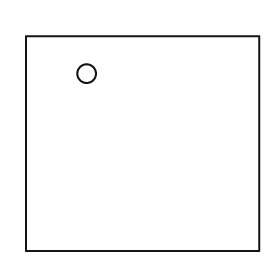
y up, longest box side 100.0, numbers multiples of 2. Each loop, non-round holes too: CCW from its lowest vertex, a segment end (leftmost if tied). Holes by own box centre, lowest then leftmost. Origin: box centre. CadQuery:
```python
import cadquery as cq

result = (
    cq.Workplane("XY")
    .moveTo(-50.0, -46.0)
    .lineTo(50.0, -46.0)
    .lineTo(50.0, 46.0)
    .lineTo(-50.0, 46.0)
    .close()
    .moveTo(-24.0, 30.0)
    .circle(4.0)
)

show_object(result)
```